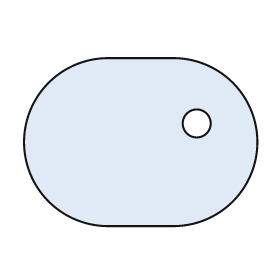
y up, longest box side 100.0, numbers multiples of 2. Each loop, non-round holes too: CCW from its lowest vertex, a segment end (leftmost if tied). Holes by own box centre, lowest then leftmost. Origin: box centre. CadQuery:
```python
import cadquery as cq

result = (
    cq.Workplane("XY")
    .moveTo(-14.0, -36.0)
    .lineTo(14.0, -36.0)
    .threePointArc((50.0, 0.0), (14.0, 36.0))
    .lineTo(-14.0, 36.0)
    .threePointArc((-50.0, 0.0), (-14.0, -36.0))
    .close()
    .moveTo(24.0, 8.0)
    .circle(6.0)
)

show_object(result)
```